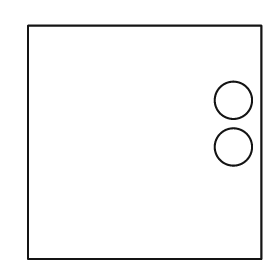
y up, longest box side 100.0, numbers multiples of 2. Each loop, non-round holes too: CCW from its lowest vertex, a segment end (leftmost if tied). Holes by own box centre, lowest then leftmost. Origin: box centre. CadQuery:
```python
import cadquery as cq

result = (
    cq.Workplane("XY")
    .moveTo(-50.0, -50.0)
    .lineTo(50.0, -50.0)
    .lineTo(50.0, 50.0)
    .lineTo(-50.0, 50.0)
    .close()
    .moveTo(38.0, -2.0)
    .circle(8.0)
    .moveTo(38.0, 18.0)
    .circle(8.0)
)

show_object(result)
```